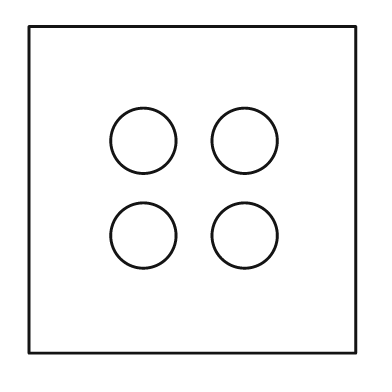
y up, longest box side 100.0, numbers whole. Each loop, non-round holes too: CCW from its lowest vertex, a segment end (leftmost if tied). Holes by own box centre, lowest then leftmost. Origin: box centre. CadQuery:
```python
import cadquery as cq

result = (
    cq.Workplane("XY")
    .moveTo(-50.0, -50.0)
    .lineTo(50.0, -50.0)
    .lineTo(50.0, 50.0)
    .lineTo(-50.0, 50.0)
    .close()
    .moveTo(-15.0, -14.0)
    .circle(10.0)
    .moveTo(16.0, -14.0)
    .circle(10.0)
    .moveTo(-15.0, 15.0)
    .circle(10.0)
    .moveTo(16.0, 15.0)
    .circle(10.0)
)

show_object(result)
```